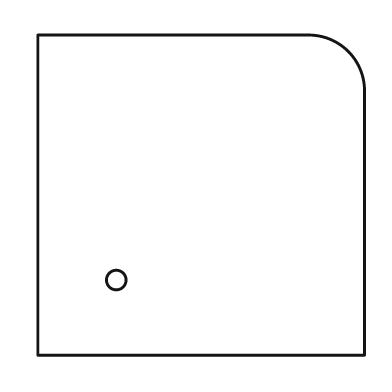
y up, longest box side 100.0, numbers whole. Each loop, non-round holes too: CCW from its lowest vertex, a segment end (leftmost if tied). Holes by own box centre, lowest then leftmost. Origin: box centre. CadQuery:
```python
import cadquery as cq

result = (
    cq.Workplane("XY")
    .moveTo(-50.0, -49.0)
    .lineTo(50.0, -49.0)
    .lineTo(50.0, 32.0)
    .threePointArc((45.0, 44.0), (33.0, 49.0))
    .lineTo(-50.0, 49.0)
    .close()
    .moveTo(-26.0, -26.0)
    .circle(3.0)
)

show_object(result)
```